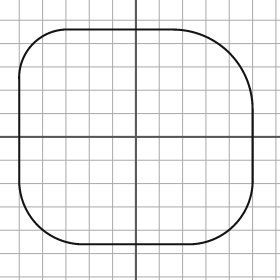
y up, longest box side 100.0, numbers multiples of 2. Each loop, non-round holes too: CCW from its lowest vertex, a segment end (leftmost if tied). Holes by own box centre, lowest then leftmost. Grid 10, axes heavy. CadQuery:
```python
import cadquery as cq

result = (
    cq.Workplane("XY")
    .moveTo(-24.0, -46.0)
    .lineTo(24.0, -46.0)
    .threePointArc((42.0, -38.0), (50.0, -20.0))
    .lineTo(50.0, 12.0)
    .threePointArc((40.0, 36.0), (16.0, 46.0))
    .lineTo(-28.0, 46.0)
    .threePointArc((-44.0, 40.0), (-50.0, 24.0))
    .lineTo(-50.0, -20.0)
    .threePointArc((-42.0, -38.0), (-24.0, -46.0))
    .close()
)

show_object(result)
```